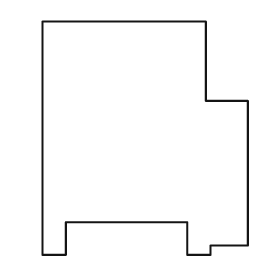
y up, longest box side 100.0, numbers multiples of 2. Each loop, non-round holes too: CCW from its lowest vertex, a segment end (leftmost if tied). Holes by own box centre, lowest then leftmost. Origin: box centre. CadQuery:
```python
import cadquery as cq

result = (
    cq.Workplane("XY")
    .moveTo(-44.0, -50.0)
    .lineTo(-34.0, -50.0)
    .lineTo(-34.0, -36.0)
    .lineTo(18.0, -36.0)
    .lineTo(18.0, -50.0)
    .lineTo(28.0, -50.0)
    .lineTo(28.0, -46.0)
    .lineTo(44.0, -46.0)
    .lineTo(44.0, 16.0)
    .lineTo(26.0, 16.0)
    .lineTo(26.0, 50.0)
    .lineTo(-44.0, 50.0)
    .close()
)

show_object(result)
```